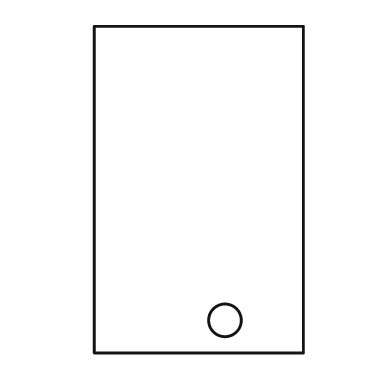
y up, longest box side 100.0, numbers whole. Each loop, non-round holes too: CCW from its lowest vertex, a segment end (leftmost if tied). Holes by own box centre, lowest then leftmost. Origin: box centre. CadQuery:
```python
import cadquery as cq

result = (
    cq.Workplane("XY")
    .moveTo(-32.0, -50.0)
    .lineTo(32.0, -50.0)
    .lineTo(32.0, 50.0)
    .lineTo(-32.0, 50.0)
    .close()
    .moveTo(8.0, -40.0)
    .circle(5.0)
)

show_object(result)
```